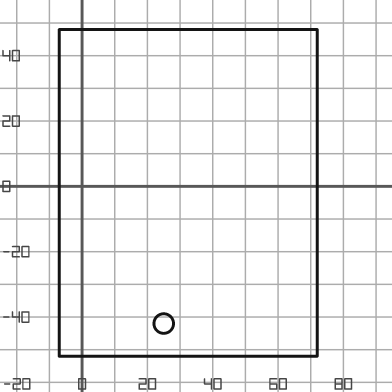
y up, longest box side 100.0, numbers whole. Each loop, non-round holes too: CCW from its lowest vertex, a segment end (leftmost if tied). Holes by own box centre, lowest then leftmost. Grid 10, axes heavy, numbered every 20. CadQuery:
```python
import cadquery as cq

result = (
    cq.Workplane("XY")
    .moveTo(-7.0, -52.0)
    .lineTo(72.0, -52.0)
    .lineTo(72.0, 48.0)
    .lineTo(-7.0, 48.0)
    .close()
    .moveTo(25.0, -42.0)
    .circle(3.0)
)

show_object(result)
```